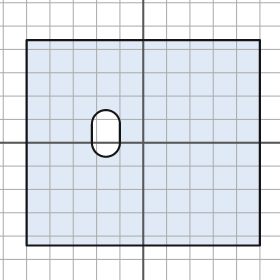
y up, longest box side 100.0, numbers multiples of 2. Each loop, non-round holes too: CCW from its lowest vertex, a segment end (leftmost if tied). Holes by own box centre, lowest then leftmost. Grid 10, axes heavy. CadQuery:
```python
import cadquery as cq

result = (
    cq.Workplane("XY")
    .moveTo(-50.0, -44.0)
    .lineTo(50.0, -44.0)
    .lineTo(50.0, 44.0)
    .lineTo(-50.0, 44.0)
    .close()
    .moveTo(-22.0, 0.0)
    .threePointArc((-16.0, -6.0), (-10.0, 0.0))
    .lineTo(-10.0, 8.0)
    .threePointArc((-16.0, 14.0), (-22.0, 8.0))
    .close()
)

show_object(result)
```